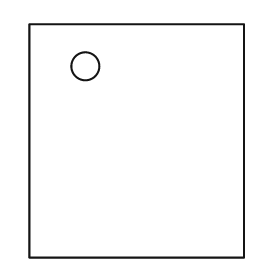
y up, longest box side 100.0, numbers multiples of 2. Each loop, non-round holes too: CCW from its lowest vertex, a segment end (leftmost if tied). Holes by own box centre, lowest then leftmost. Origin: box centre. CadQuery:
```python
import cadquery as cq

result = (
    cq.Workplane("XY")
    .moveTo(-46.0, -50.0)
    .lineTo(46.0, -50.0)
    .lineTo(46.0, 50.0)
    .lineTo(-46.0, 50.0)
    .close()
    .moveTo(-22.0, 32.0)
    .circle(6.0)
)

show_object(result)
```